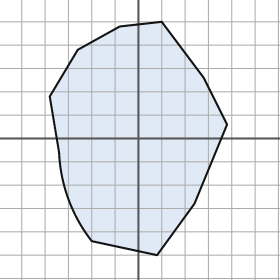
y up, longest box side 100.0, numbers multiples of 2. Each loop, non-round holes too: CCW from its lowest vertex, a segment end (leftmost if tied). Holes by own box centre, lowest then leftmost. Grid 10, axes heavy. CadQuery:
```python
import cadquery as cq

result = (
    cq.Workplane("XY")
    .moveTo(8.0, -50.0)
    .lineTo(24.0, -28.0)
    .lineTo(38.0, 6.0)
    .lineTo(28.0, 26.0)
    .lineTo(10.0, 50.0)
    .lineTo(-8.0, 48.0)
    .lineTo(-26.0, 38.0)
    .lineTo(-38.0, 18.0)
    .lineTo(-34.0, -6.0)
    .threePointArc((-30.0, -26.0), (-20.0, -44.0))
    .close()
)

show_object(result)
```